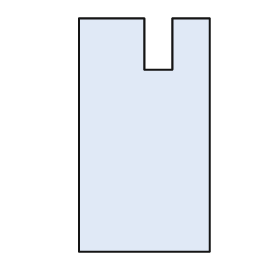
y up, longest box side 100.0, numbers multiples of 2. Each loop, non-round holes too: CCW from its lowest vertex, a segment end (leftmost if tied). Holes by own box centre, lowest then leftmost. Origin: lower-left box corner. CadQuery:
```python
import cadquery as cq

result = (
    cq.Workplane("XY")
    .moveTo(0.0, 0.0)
    .lineTo(56.0, 0.0)
    .lineTo(56.0, 100.0)
    .lineTo(40.0, 100.0)
    .lineTo(40.0, 78.0)
    .lineTo(28.0, 78.0)
    .lineTo(28.0, 100.0)
    .lineTo(0.0, 100.0)
    .close()
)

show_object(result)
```